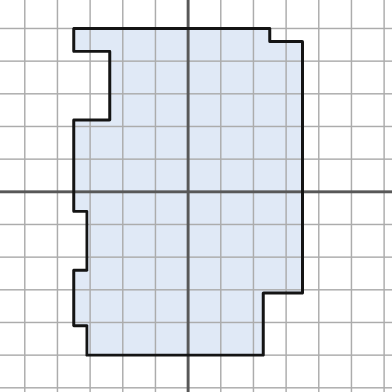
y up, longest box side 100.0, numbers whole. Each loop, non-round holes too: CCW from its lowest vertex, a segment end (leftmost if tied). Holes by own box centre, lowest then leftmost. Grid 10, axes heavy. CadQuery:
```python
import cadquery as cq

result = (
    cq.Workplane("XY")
    .moveTo(-31.0, -50.0)
    .lineTo(23.0, -50.0)
    .lineTo(23.0, -31.0)
    .lineTo(35.0, -31.0)
    .lineTo(35.0, 46.0)
    .lineTo(25.0, 46.0)
    .lineTo(25.0, 50.0)
    .lineTo(-35.0, 50.0)
    .lineTo(-35.0, 43.0)
    .lineTo(-24.0, 43.0)
    .lineTo(-24.0, 22.0)
    .lineTo(-35.0, 22.0)
    .lineTo(-35.0, -6.0)
    .lineTo(-31.0, -6.0)
    .lineTo(-31.0, -24.0)
    .lineTo(-35.0, -24.0)
    .lineTo(-35.0, -41.0)
    .lineTo(-31.0, -41.0)
    .close()
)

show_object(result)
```